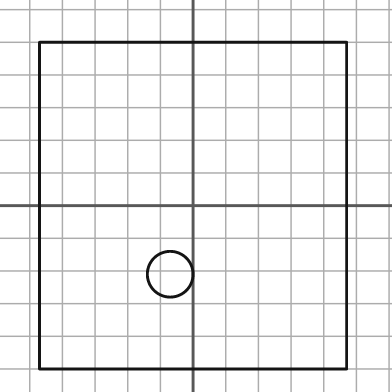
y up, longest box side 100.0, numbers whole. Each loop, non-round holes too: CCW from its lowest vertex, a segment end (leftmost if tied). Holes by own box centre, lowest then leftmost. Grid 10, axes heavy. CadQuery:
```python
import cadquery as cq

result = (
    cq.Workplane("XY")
    .moveTo(-47.0, -50.0)
    .lineTo(47.0, -50.0)
    .lineTo(47.0, 50.0)
    .lineTo(-47.0, 50.0)
    .close()
    .moveTo(-7.0, -21.0)
    .circle(7.0)
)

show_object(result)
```